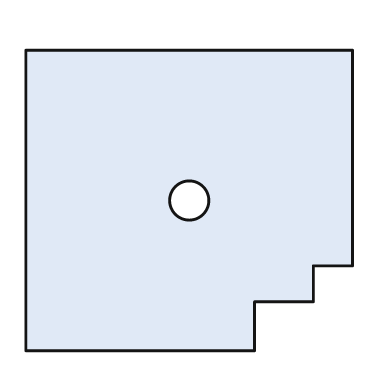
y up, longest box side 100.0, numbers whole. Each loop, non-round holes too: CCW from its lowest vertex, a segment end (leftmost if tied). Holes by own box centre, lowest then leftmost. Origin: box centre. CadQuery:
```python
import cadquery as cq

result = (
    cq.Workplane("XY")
    .moveTo(-50.0, -46.0)
    .lineTo(20.0, -46.0)
    .lineTo(20.0, -31.0)
    .lineTo(38.0, -31.0)
    .lineTo(38.0, -20.0)
    .lineTo(50.0, -20.0)
    .lineTo(50.0, 46.0)
    .lineTo(-50.0, 46.0)
    .close()
    .moveTo(0.0, 0.0)
    .circle(6.0)
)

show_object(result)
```